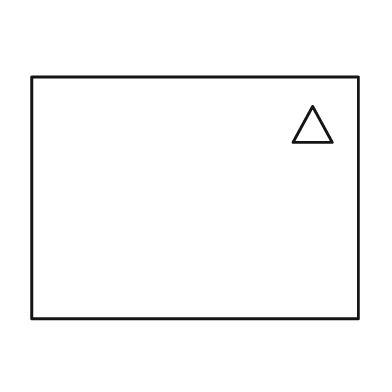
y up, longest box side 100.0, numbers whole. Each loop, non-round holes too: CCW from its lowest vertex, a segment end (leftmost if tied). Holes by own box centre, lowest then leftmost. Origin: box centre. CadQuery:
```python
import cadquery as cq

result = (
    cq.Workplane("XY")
    .moveTo(-50.0, -37.0)
    .lineTo(50.0, -37.0)
    .lineTo(50.0, 37.0)
    .lineTo(-50.0, 37.0)
    .close()
    .moveTo(30.0, 17.0)
    .lineTo(42.0, 17.0)
    .lineTo(36.0, 28.0)
    .close()
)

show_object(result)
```